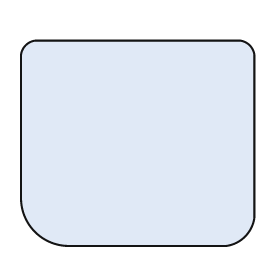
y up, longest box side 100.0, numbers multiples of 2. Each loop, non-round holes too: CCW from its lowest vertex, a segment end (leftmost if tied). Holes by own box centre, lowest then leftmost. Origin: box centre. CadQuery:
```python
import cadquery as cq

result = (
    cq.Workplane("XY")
    .moveTo(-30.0, -44.0)
    .lineTo(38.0, -44.0)
    .threePointArc((46.0, -40.0), (50.0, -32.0))
    .lineTo(50.0, 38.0)
    .threePointArc((48.0, 42.0), (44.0, 44.0))
    .lineTo(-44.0, 44.0)
    .threePointArc((-48.0, 42.0), (-50.0, 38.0))
    .lineTo(-50.0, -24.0)
    .threePointArc((-44.0, -38.0), (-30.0, -44.0))
    .close()
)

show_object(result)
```